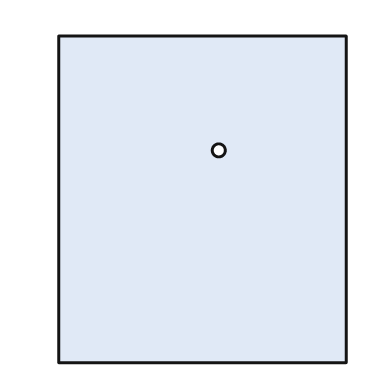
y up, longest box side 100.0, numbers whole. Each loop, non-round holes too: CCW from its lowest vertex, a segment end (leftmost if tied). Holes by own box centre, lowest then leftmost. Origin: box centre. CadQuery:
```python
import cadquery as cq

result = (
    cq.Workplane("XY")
    .moveTo(-44.0, -50.0)
    .lineTo(44.0, -50.0)
    .lineTo(44.0, 50.0)
    .lineTo(-44.0, 50.0)
    .close()
    .moveTo(5.0, 15.0)
    .circle(2.0)
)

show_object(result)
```